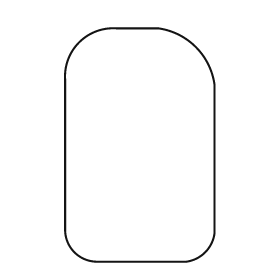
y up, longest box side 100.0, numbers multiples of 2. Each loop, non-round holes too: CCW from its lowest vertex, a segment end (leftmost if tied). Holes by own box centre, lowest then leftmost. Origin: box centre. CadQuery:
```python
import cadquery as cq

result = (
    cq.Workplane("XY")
    .moveTo(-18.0, -50.0)
    .lineTo(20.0, -50.0)
    .threePointArc((28.0, -46.0), (32.0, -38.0))
    .lineTo(32.0, 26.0)
    .threePointArc((24.0, 42.0), (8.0, 50.0))
    .lineTo(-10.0, 50.0)
    .threePointArc((-26.0, 44.0), (-32.0, 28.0))
    .lineTo(-32.0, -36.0)
    .threePointArc((-28.0, -46.0), (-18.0, -50.0))
    .close()
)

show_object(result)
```